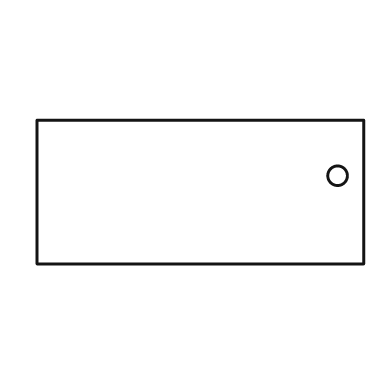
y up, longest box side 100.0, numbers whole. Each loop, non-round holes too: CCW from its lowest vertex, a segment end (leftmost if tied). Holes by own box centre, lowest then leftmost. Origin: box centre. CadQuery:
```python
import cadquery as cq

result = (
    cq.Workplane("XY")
    .moveTo(-50.0, -22.0)
    .lineTo(50.0, -22.0)
    .lineTo(50.0, 22.0)
    .lineTo(-50.0, 22.0)
    .close()
    .moveTo(42.0, 5.0)
    .circle(3.0)
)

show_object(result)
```